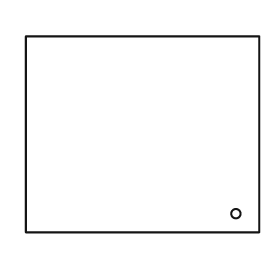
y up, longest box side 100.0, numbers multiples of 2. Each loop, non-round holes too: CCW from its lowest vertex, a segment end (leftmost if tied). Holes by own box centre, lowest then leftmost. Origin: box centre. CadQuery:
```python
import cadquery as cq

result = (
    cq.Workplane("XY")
    .moveTo(-50.0, -42.0)
    .lineTo(50.0, -42.0)
    .lineTo(50.0, 42.0)
    .lineTo(-50.0, 42.0)
    .close()
    .moveTo(40.0, -34.0)
    .circle(2.0)
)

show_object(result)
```